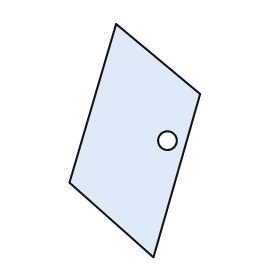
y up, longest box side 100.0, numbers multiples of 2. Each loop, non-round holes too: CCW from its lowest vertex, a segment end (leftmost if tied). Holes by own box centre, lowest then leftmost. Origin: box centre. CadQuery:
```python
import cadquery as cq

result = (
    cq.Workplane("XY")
    .moveTo(8.0, -50.0)
    .lineTo(28.0, 20.0)
    .lineTo(-8.0, 50.0)
    .lineTo(-28.0, -18.0)
    .close()
    .moveTo(14.0, 0.0)
    .circle(4.0)
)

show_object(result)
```